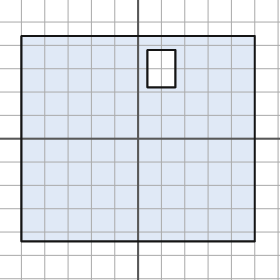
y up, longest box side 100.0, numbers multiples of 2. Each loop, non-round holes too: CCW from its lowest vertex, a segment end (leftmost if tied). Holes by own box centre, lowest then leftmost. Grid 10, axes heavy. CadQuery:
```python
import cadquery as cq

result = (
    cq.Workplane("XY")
    .moveTo(-50.0, -44.0)
    .lineTo(50.0, -44.0)
    .lineTo(50.0, 44.0)
    .lineTo(-50.0, 44.0)
    .close()
    .moveTo(4.0, 22.0)
    .lineTo(16.0, 22.0)
    .lineTo(16.0, 38.0)
    .lineTo(4.0, 38.0)
    .close()
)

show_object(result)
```